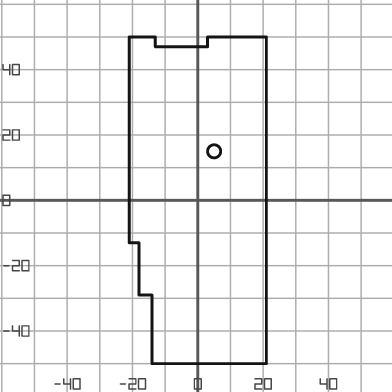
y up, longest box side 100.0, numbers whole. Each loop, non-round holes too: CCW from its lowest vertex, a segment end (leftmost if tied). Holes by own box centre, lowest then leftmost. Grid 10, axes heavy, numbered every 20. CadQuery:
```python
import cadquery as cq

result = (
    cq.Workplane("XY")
    .moveTo(-14.0, -50.0)
    .lineTo(21.0, -50.0)
    .lineTo(21.0, 50.0)
    .lineTo(3.0, 50.0)
    .lineTo(3.0, 47.0)
    .lineTo(-13.0, 47.0)
    .lineTo(-13.0, 50.0)
    .lineTo(-21.0, 50.0)
    .lineTo(-21.0, -13.0)
    .lineTo(-18.0, -13.0)
    .lineTo(-18.0, -29.0)
    .lineTo(-14.0, -29.0)
    .close()
    .moveTo(5.0, 15.0)
    .circle(2.0)
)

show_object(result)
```